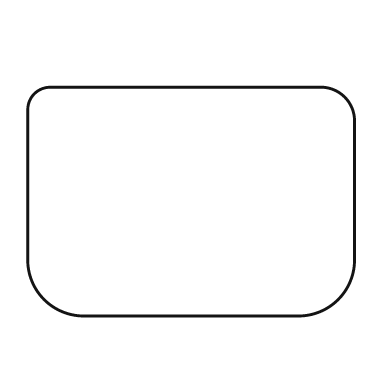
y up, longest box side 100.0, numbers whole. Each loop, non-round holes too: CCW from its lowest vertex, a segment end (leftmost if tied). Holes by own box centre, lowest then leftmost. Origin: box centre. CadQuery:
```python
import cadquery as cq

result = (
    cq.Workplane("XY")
    .moveTo(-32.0, -35.0)
    .lineTo(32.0, -35.0)
    .threePointArc((45.0, -30.0), (50.0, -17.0))
    .lineTo(50.0, 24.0)
    .threePointArc((47.0, 32.0), (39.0, 35.0))
    .lineTo(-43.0, 35.0)
    .threePointArc((-48.0, 33.0), (-50.0, 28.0))
    .lineTo(-50.0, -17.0)
    .threePointArc((-45.0, -30.0), (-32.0, -35.0))
    .close()
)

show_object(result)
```